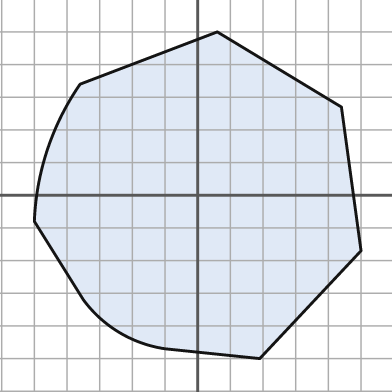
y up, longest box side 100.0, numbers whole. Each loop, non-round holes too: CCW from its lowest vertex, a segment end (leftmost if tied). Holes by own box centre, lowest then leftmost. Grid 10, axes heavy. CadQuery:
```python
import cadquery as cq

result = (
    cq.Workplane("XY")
    .moveTo(19.0, -50.0)
    .lineTo(50.0, -17.0)
    .lineTo(44.0, 27.0)
    .lineTo(6.0, 50.0)
    .lineTo(-36.0, 34.0)
    .threePointArc((-46.0, 14.0), (-50.0, -8.0))
    .lineTo(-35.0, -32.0)
    .threePointArc((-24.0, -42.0), (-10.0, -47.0))
    .close()
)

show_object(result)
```